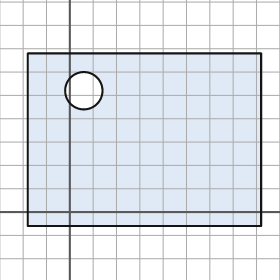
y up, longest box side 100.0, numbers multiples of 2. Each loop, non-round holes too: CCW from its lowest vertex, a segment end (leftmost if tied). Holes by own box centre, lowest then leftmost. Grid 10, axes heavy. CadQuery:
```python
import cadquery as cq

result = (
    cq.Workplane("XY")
    .moveTo(-18.0, -6.0)
    .lineTo(82.0, -6.0)
    .lineTo(82.0, 68.0)
    .lineTo(-18.0, 68.0)
    .close()
    .moveTo(6.0, 52.0)
    .circle(8.0)
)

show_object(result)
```